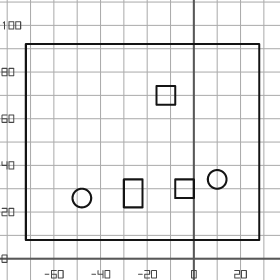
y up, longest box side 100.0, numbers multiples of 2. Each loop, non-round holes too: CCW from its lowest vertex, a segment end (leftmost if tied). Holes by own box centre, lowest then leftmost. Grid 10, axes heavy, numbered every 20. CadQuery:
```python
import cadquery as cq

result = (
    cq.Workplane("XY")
    .moveTo(-72.0, 8.0)
    .lineTo(28.0, 8.0)
    .lineTo(28.0, 92.0)
    .lineTo(-72.0, 92.0)
    .close()
    .moveTo(-48.0, 26.0)
    .circle(4.0)
    .moveTo(-30.0, 22.0)
    .lineTo(-22.0, 22.0)
    .lineTo(-22.0, 34.0)
    .lineTo(-30.0, 34.0)
    .close()
    .moveTo(-8.0, 26.0)
    .lineTo(0.0, 26.0)
    .lineTo(0.0, 34.0)
    .lineTo(-8.0, 34.0)
    .close()
    .moveTo(10.0, 34.0)
    .circle(4.0)
    .moveTo(-16.0, 66.0)
    .lineTo(-8.0, 66.0)
    .lineTo(-8.0, 74.0)
    .lineTo(-16.0, 74.0)
    .close()
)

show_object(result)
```